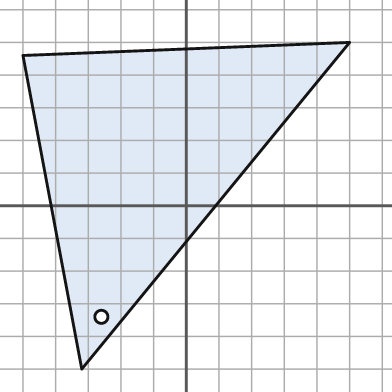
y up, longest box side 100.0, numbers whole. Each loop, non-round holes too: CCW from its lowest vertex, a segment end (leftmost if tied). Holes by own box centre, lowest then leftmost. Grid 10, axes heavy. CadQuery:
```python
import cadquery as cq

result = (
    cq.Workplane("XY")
    .moveTo(-32.0, -50.0)
    .lineTo(50.0, 50.0)
    .lineTo(-50.0, 46.0)
    .close()
    .moveTo(-26.0, -34.0)
    .circle(2.0)
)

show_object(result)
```